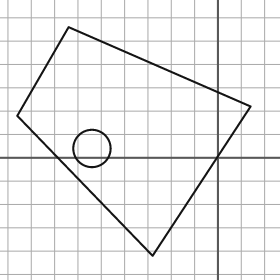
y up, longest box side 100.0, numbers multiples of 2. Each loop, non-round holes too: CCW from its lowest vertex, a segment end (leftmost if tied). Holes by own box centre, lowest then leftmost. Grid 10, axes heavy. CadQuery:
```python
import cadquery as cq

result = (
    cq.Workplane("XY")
    .moveTo(-28.0, -42.0)
    .lineTo(14.0, 22.0)
    .lineTo(-64.0, 56.0)
    .lineTo(-86.0, 18.0)
    .close()
    .moveTo(-54.0, 4.0)
    .circle(8.0)
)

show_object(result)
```